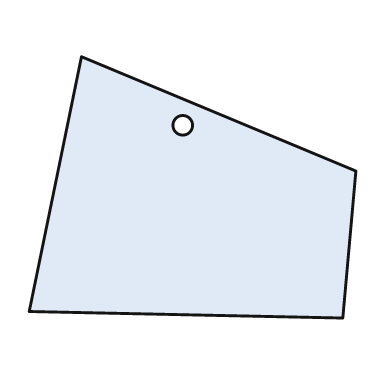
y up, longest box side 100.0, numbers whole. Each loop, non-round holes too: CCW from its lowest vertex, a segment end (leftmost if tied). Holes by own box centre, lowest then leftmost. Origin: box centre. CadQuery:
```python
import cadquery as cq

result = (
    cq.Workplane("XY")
    .moveTo(46.0, -40.0)
    .lineTo(50.0, 5.0)
    .lineTo(-34.0, 40.0)
    .lineTo(-50.0, -38.0)
    .close()
    .moveTo(-3.0, 19.0)
    .circle(3.0)
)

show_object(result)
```